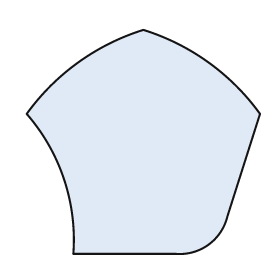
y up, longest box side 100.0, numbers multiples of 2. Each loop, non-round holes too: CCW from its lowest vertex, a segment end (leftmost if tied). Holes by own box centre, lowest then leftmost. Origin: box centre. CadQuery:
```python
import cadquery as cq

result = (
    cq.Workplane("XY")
    .moveTo(-30.0, -48.0)
    .lineTo(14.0, -48.0)
    .threePointArc((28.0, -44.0), (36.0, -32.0))
    .lineTo(50.0, 12.0)
    .threePointArc((28.0, 34.0), (0.0, 48.0))
    .threePointArc((-28.0, 34.0), (-50.0, 12.0))
    .threePointArc((-34.0, -16.0), (-30.0, -48.0))
    .close()
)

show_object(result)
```